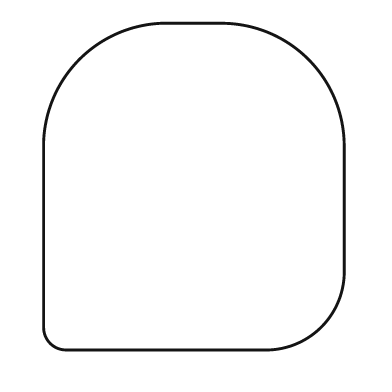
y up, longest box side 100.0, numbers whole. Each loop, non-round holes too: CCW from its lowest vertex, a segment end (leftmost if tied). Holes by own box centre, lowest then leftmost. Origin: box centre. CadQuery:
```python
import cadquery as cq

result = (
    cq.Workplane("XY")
    .moveTo(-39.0, -50.0)
    .lineTo(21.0, -50.0)
    .threePointArc((39.0, -43.0), (46.0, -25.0))
    .lineTo(46.0, 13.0)
    .threePointArc((35.0, 39.0), (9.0, 50.0))
    .lineTo(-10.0, 50.0)
    .threePointArc((-35.0, 39.0), (-46.0, 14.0))
    .lineTo(-46.0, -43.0)
    .threePointArc((-44.0, -48.0), (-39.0, -50.0))
    .close()
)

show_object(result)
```